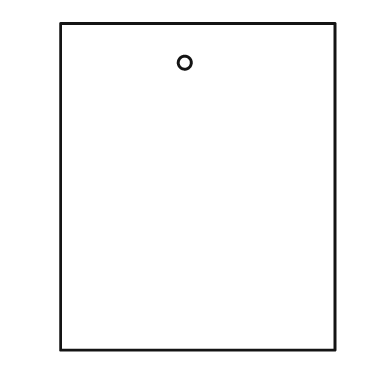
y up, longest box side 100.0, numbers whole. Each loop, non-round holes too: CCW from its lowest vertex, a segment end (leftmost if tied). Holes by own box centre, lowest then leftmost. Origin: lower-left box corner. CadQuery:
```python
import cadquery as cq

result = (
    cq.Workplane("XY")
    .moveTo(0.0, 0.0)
    .lineTo(84.0, 0.0)
    .lineTo(84.0, 100.0)
    .lineTo(0.0, 100.0)
    .close()
    .moveTo(38.0, 88.0)
    .circle(2.0)
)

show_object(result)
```